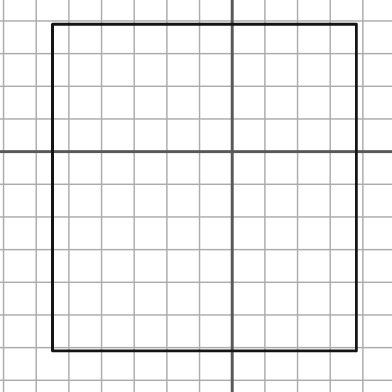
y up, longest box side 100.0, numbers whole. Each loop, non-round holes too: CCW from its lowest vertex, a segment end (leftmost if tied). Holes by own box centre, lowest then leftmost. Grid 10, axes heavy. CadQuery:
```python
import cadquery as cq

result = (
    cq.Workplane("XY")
    .moveTo(-55.0, -61.0)
    .lineTo(38.0, -61.0)
    .lineTo(38.0, 39.0)
    .lineTo(-55.0, 39.0)
    .close()
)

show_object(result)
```